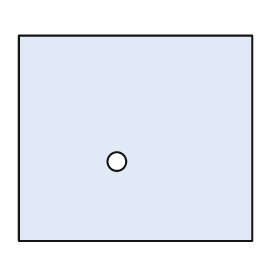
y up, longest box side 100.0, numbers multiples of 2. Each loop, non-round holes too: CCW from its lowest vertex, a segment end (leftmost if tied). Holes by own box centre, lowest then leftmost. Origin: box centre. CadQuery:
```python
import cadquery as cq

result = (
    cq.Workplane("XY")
    .moveTo(-50.0, -44.0)
    .lineTo(50.0, -44.0)
    .lineTo(50.0, 44.0)
    .lineTo(-50.0, 44.0)
    .close()
    .moveTo(-8.0, -10.0)
    .circle(4.0)
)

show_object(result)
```